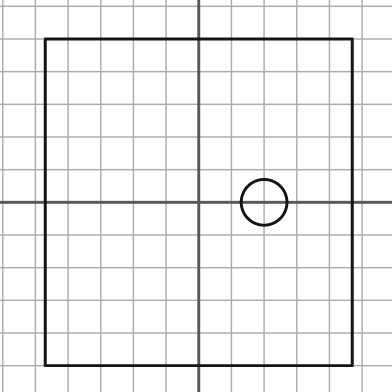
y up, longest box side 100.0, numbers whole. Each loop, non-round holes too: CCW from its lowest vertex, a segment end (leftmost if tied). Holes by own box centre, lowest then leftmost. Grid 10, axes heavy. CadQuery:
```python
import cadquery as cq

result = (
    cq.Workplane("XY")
    .moveTo(-47.0, -50.0)
    .lineTo(47.0, -50.0)
    .lineTo(47.0, 50.0)
    .lineTo(-47.0, 50.0)
    .close()
    .moveTo(20.0, 0.0)
    .circle(7.0)
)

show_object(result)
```